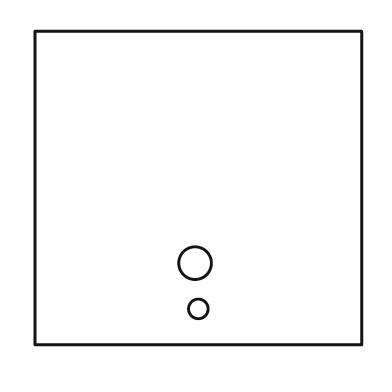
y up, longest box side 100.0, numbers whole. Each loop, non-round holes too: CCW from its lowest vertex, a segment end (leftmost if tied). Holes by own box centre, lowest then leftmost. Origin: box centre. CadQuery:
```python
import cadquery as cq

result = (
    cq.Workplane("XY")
    .moveTo(-50.0, -48.0)
    .lineTo(50.0, -48.0)
    .lineTo(50.0, 48.0)
    .lineTo(-50.0, 48.0)
    .close()
    .moveTo(0.0, -37.0)
    .circle(3.0)
    .moveTo(-1.0, -23.0)
    .circle(5.0)
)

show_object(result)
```